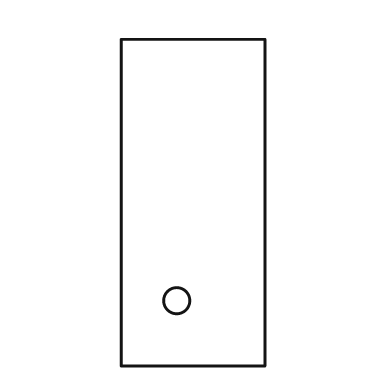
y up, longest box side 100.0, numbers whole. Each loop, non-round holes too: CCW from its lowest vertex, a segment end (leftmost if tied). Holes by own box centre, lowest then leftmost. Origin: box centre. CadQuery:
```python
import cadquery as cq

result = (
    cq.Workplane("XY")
    .moveTo(-22.0, -50.0)
    .lineTo(22.0, -50.0)
    .lineTo(22.0, 50.0)
    .lineTo(-22.0, 50.0)
    .close()
    .moveTo(-5.0, -30.0)
    .circle(4.0)
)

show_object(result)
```